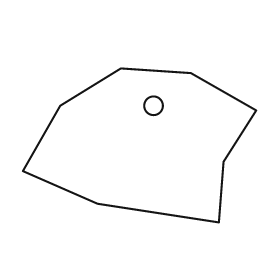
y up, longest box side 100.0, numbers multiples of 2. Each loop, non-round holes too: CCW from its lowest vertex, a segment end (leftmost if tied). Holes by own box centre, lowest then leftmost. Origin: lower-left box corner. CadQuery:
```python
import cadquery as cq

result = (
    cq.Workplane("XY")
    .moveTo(84.0, 0.0)
    .lineTo(86.0, 26.0)
    .lineTo(100.0, 48.0)
    .lineTo(72.0, 64.0)
    .lineTo(42.0, 66.0)
    .lineTo(16.0, 50.0)
    .lineTo(0.0, 22.0)
    .lineTo(32.0, 8.0)
    .close()
    .moveTo(56.0, 50.0)
    .circle(4.0)
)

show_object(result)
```